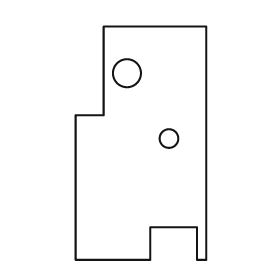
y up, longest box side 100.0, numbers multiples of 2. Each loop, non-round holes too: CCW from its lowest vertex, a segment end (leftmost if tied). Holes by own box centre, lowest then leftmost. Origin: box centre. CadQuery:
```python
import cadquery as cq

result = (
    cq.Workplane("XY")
    .moveTo(-28.0, -50.0)
    .lineTo(4.0, -50.0)
    .lineTo(4.0, -36.0)
    .lineTo(24.0, -36.0)
    .lineTo(24.0, -50.0)
    .lineTo(28.0, -50.0)
    .lineTo(28.0, 50.0)
    .lineTo(-16.0, 50.0)
    .lineTo(-16.0, 12.0)
    .lineTo(-28.0, 12.0)
    .close()
    .moveTo(12.0, 2.0)
    .circle(4.0)
    .moveTo(-6.0, 30.0)
    .circle(6.0)
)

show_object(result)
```